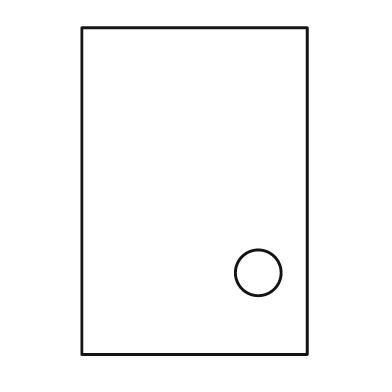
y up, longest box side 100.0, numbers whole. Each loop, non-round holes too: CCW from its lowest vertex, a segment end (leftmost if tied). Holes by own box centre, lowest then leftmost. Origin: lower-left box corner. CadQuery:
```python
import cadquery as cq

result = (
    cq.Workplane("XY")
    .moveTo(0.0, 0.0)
    .lineTo(69.0, 0.0)
    .lineTo(69.0, 100.0)
    .lineTo(0.0, 100.0)
    .close()
    .moveTo(54.0, 25.0)
    .circle(7.0)
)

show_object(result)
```